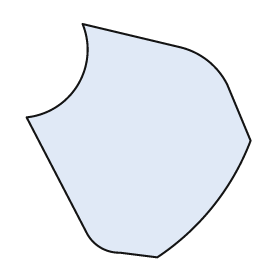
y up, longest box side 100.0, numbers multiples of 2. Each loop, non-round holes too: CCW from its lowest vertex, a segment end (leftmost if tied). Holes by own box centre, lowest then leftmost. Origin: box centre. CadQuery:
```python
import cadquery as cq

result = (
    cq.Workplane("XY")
    .moveTo(8.0, -50.0)
    .threePointArc((32.0, -28.0), (48.0, 0.0))
    .lineTo(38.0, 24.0)
    .threePointArc((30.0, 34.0), (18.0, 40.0))
    .lineTo(-24.0, 50.0)
    .threePointArc((-26.0, 24.0), (-48.0, 10.0))
    .lineTo(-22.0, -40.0)
    .threePointArc((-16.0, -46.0), (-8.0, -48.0))
    .close()
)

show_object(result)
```